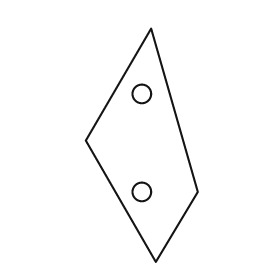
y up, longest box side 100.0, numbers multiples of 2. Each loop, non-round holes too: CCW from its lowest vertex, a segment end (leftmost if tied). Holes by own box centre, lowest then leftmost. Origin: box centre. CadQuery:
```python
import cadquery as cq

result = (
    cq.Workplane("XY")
    .moveTo(6.0, -50.0)
    .lineTo(24.0, -20.0)
    .lineTo(4.0, 50.0)
    .lineTo(-24.0, 2.0)
    .close()
    .moveTo(0.0, -20.0)
    .circle(4.0)
    .moveTo(0.0, 22.0)
    .circle(4.0)
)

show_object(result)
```